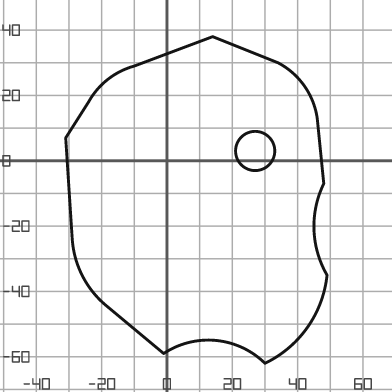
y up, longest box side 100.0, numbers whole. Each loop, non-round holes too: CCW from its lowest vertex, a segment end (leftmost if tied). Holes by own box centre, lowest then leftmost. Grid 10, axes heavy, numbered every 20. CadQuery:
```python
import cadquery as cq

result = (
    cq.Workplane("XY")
    .moveTo(30.0, -62.0)
    .threePointArc((43.0, -51.0), (49.0, -35.0))
    .threePointArc((45.0, -21.0), (48.0, -7.0))
    .lineTo(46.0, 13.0)
    .threePointArc((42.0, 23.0), (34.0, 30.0))
    .lineTo(14.0, 38.0)
    .lineTo(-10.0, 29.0)
    .threePointArc((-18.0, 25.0), (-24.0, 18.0))
    .lineTo(-31.0, 7.0)
    .lineTo(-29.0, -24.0)
    .threePointArc((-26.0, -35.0), (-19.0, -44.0))
    .lineTo(-1.0, -59.0)
    .threePointArc((15.0, -55.0), (30.0, -62.0))
    .close()
    .moveTo(27.0, 3.0)
    .circle(6.0)
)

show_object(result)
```